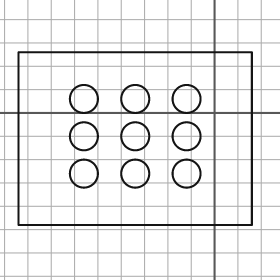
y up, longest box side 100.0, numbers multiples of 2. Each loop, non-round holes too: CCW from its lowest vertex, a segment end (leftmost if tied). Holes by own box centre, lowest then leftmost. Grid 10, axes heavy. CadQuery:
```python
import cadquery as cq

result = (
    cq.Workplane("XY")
    .moveTo(-84.0, -48.0)
    .lineTo(16.0, -48.0)
    .lineTo(16.0, 26.0)
    .lineTo(-84.0, 26.0)
    .close()
    .moveTo(-56.0, -26.0)
    .circle(6.0)
    .moveTo(-34.0, -26.0)
    .circle(6.0)
    .moveTo(-12.0, -26.0)
    .circle(6.0)
    .moveTo(-56.0, -10.0)
    .circle(6.0)
    .moveTo(-34.0, -10.0)
    .circle(6.0)
    .moveTo(-12.0, -10.0)
    .circle(6.0)
    .moveTo(-56.0, 6.0)
    .circle(6.0)
    .moveTo(-34.0, 6.0)
    .circle(6.0)
    .moveTo(-12.0, 6.0)
    .circle(6.0)
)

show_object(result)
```